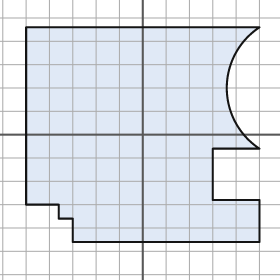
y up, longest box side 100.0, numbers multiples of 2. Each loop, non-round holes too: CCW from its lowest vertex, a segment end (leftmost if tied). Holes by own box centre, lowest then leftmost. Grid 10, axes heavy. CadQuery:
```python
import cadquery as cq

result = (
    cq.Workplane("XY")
    .moveTo(-30.0, -46.0)
    .lineTo(50.0, -46.0)
    .lineTo(50.0, -28.0)
    .lineTo(30.0, -28.0)
    .lineTo(30.0, -6.0)
    .lineTo(50.0, -6.0)
    .threePointArc((36.0, 20.0), (50.0, 46.0))
    .lineTo(-50.0, 46.0)
    .lineTo(-50.0, -30.0)
    .lineTo(-36.0, -30.0)
    .lineTo(-36.0, -36.0)
    .lineTo(-30.0, -36.0)
    .close()
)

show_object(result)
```